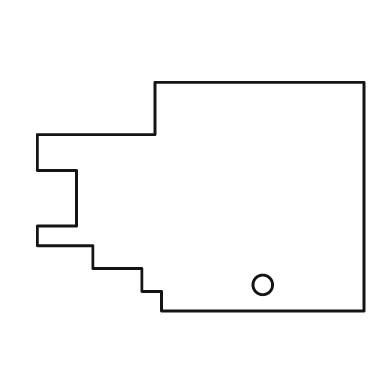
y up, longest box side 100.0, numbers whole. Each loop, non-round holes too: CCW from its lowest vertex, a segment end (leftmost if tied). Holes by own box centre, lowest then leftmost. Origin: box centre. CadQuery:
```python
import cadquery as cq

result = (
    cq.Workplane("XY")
    .moveTo(-12.0, -35.0)
    .lineTo(50.0, -35.0)
    .lineTo(50.0, 35.0)
    .lineTo(-14.0, 35.0)
    .lineTo(-14.0, 19.0)
    .lineTo(-50.0, 19.0)
    .lineTo(-50.0, 8.0)
    .lineTo(-38.0, 8.0)
    .lineTo(-38.0, -9.0)
    .lineTo(-50.0, -9.0)
    .lineTo(-50.0, -15.0)
    .lineTo(-33.0, -15.0)
    .lineTo(-33.0, -22.0)
    .lineTo(-18.0, -22.0)
    .lineTo(-18.0, -29.0)
    .lineTo(-12.0, -29.0)
    .close()
    .moveTo(19.0, -27.0)
    .circle(3.0)
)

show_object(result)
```